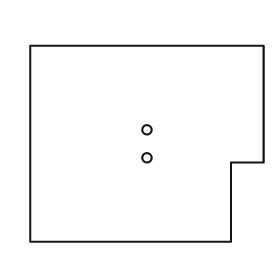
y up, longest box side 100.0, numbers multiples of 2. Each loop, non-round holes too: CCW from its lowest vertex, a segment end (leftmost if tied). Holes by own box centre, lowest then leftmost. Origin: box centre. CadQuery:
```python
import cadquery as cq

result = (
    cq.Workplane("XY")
    .moveTo(-50.0, -42.0)
    .lineTo(36.0, -42.0)
    .lineTo(36.0, -8.0)
    .lineTo(50.0, -8.0)
    .lineTo(50.0, 42.0)
    .lineTo(-50.0, 42.0)
    .close()
    .moveTo(0.0, -6.0)
    .circle(2.0)
    .moveTo(0.0, 6.0)
    .circle(2.0)
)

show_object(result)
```